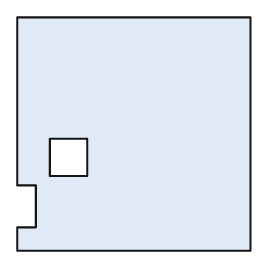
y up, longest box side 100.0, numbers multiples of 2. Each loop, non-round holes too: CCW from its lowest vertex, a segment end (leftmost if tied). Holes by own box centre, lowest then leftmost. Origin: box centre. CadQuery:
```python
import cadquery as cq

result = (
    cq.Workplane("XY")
    .moveTo(-50.0, -50.0)
    .lineTo(50.0, -50.0)
    .lineTo(50.0, 50.0)
    .lineTo(-50.0, 50.0)
    .lineTo(-50.0, -22.0)
    .lineTo(-42.0, -22.0)
    .lineTo(-42.0, -40.0)
    .lineTo(-50.0, -40.0)
    .close()
    .moveTo(-36.0, -18.0)
    .lineTo(-20.0, -18.0)
    .lineTo(-20.0, -2.0)
    .lineTo(-36.0, -2.0)
    .close()
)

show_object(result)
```